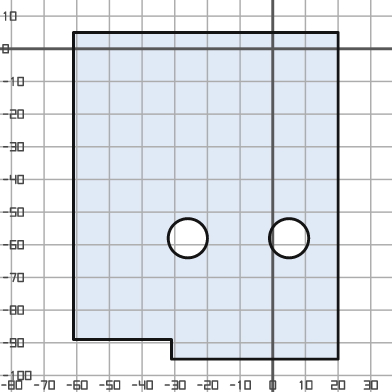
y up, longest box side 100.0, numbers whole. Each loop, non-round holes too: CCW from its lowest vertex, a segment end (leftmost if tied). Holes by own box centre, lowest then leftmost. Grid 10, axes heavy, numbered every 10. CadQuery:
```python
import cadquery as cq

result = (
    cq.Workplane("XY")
    .moveTo(-31.0, -95.0)
    .lineTo(20.0, -95.0)
    .lineTo(20.0, 5.0)
    .lineTo(-61.0, 5.0)
    .lineTo(-61.0, -89.0)
    .lineTo(-31.0, -89.0)
    .close()
    .moveTo(-26.0, -58.0)
    .circle(6.0)
    .moveTo(5.0, -58.0)
    .circle(6.0)
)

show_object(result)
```